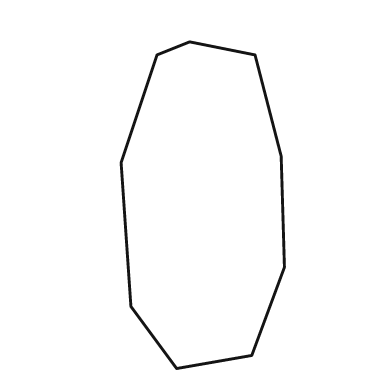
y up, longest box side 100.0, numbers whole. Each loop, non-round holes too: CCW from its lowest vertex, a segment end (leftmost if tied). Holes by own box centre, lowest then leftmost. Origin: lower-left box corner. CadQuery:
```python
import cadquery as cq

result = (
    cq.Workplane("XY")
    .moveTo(17.0, 0.0)
    .lineTo(40.0, 4.0)
    .lineTo(50.0, 31.0)
    .lineTo(49.0, 65.0)
    .lineTo(41.0, 96.0)
    .lineTo(21.0, 100.0)
    .lineTo(11.0, 96.0)
    .lineTo(0.0, 63.0)
    .lineTo(3.0, 19.0)
    .close()
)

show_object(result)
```